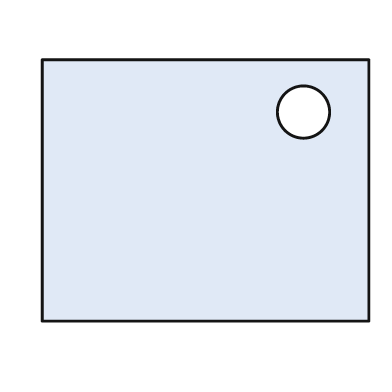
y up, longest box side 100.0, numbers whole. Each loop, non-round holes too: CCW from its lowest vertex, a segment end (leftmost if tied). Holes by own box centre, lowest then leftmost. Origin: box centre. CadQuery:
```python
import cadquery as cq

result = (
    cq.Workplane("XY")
    .moveTo(-50.0, -40.0)
    .lineTo(50.0, -40.0)
    .lineTo(50.0, 40.0)
    .lineTo(-50.0, 40.0)
    .close()
    .moveTo(30.0, 24.0)
    .circle(8.0)
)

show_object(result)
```